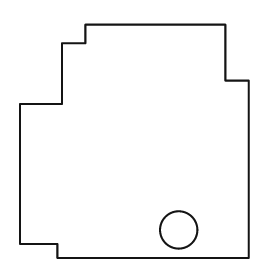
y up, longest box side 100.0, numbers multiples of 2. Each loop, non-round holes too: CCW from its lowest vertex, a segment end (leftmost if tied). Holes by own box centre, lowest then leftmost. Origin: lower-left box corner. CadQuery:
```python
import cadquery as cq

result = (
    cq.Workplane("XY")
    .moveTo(16.0, 0.0)
    .lineTo(98.0, 0.0)
    .lineTo(98.0, 76.0)
    .lineTo(88.0, 76.0)
    .lineTo(88.0, 100.0)
    .lineTo(28.0, 100.0)
    .lineTo(28.0, 92.0)
    .lineTo(18.0, 92.0)
    .lineTo(18.0, 66.0)
    .lineTo(0.0, 66.0)
    .lineTo(0.0, 6.0)
    .lineTo(16.0, 6.0)
    .close()
    .moveTo(68.0, 12.0)
    .circle(8.0)
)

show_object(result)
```